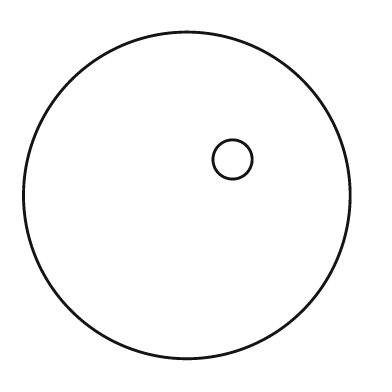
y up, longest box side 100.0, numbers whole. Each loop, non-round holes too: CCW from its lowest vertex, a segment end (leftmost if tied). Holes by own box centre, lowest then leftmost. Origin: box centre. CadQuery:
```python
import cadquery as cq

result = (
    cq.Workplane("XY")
    .moveTo(0.0, 0.0)
    .circle(50.0)
    .moveTo(14.0, 11.0)
    .circle(6.0)
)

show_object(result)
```